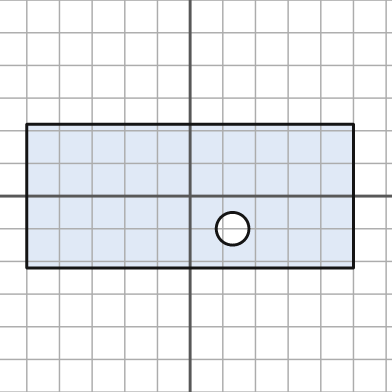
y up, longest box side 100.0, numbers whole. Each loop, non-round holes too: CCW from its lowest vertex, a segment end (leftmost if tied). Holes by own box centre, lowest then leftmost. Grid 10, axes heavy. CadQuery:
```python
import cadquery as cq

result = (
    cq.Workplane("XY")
    .moveTo(-50.0, -22.0)
    .lineTo(50.0, -22.0)
    .lineTo(50.0, 22.0)
    .lineTo(-50.0, 22.0)
    .close()
    .moveTo(13.0, -10.0)
    .circle(5.0)
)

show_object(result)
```